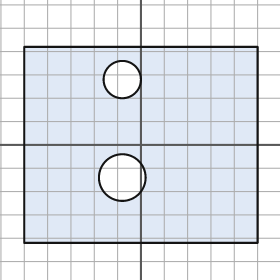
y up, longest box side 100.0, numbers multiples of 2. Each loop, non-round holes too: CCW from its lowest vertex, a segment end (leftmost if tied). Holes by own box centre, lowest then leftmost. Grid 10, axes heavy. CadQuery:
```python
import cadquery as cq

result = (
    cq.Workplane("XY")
    .moveTo(-50.0, -42.0)
    .lineTo(50.0, -42.0)
    .lineTo(50.0, 42.0)
    .lineTo(-50.0, 42.0)
    .close()
    .moveTo(-8.0, -14.0)
    .circle(10.0)
    .moveTo(-8.0, 28.0)
    .circle(8.0)
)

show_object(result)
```